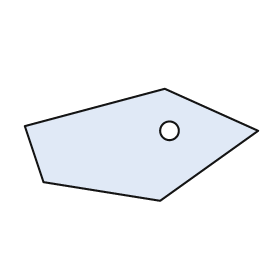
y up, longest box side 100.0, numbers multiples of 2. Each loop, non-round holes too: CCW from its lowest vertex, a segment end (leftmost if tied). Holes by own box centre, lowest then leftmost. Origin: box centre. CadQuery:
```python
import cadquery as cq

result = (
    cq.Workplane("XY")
    .moveTo(8.0, -24.0)
    .lineTo(50.0, 6.0)
    .lineTo(10.0, 24.0)
    .lineTo(-50.0, 8.0)
    .lineTo(-42.0, -16.0)
    .close()
    .moveTo(12.0, 6.0)
    .circle(4.0)
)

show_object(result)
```